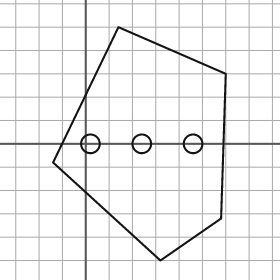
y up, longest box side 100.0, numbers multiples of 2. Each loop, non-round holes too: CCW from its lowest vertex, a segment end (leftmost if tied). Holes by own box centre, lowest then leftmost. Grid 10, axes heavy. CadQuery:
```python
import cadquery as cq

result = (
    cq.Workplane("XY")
    .moveTo(32.0, -50.0)
    .lineTo(58.0, -32.0)
    .lineTo(60.0, 30.0)
    .lineTo(14.0, 50.0)
    .lineTo(-14.0, -8.0)
    .close()
    .moveTo(2.0, 0.0)
    .circle(4.0)
    .moveTo(24.0, 0.0)
    .circle(4.0)
    .moveTo(46.0, 0.0)
    .circle(4.0)
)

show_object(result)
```